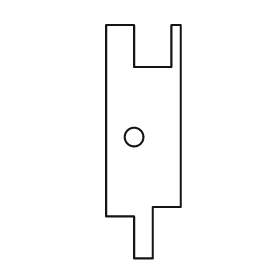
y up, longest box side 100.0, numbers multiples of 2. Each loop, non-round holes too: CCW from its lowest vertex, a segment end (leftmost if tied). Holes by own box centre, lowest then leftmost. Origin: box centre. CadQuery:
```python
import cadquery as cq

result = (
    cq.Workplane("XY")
    .moveTo(-4.0, -50.0)
    .lineTo(4.0, -50.0)
    .lineTo(4.0, -28.0)
    .lineTo(16.0, -28.0)
    .lineTo(16.0, 50.0)
    .lineTo(12.0, 50.0)
    .lineTo(12.0, 32.0)
    .lineTo(-4.0, 32.0)
    .lineTo(-4.0, 50.0)
    .lineTo(-16.0, 50.0)
    .lineTo(-16.0, -32.0)
    .lineTo(-4.0, -32.0)
    .close()
    .moveTo(-4.0, 2.0)
    .circle(4.0)
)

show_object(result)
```